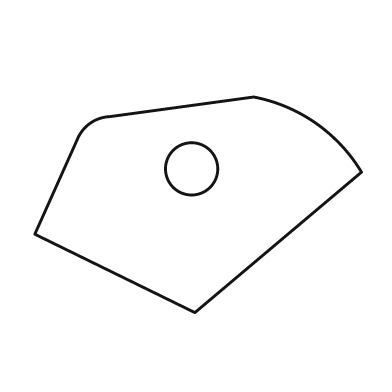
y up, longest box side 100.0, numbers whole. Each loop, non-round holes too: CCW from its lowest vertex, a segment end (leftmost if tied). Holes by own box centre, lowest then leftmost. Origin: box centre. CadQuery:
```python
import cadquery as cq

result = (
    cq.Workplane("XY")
    .moveTo(-1.0, -33.0)
    .lineTo(50.0, 10.0)
    .threePointArc((36.0, 25.0), (17.0, 33.0))
    .lineTo(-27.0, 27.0)
    .threePointArc((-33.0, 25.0), (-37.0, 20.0))
    .lineTo(-50.0, -9.0)
    .close()
    .moveTo(-2.0, 11.0)
    .circle(8.0)
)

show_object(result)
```